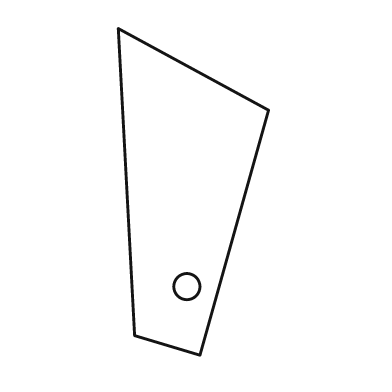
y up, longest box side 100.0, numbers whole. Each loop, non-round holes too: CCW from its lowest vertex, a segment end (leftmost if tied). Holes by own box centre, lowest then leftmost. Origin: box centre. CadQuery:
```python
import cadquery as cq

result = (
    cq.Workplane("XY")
    .moveTo(2.0, -50.0)
    .lineTo(23.0, 25.0)
    .lineTo(-23.0, 50.0)
    .lineTo(-18.0, -44.0)
    .close()
    .moveTo(-2.0, -29.0)
    .circle(4.0)
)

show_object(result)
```